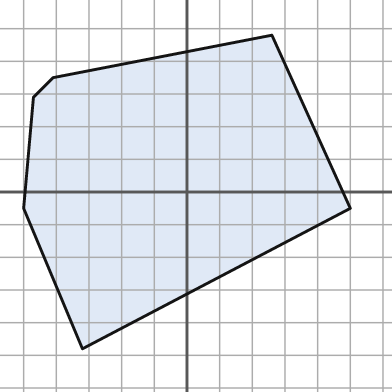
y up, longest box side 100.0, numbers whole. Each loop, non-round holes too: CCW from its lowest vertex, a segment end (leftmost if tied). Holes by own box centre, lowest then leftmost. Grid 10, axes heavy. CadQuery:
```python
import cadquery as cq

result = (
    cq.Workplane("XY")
    .moveTo(-32.0, -48.0)
    .lineTo(50.0, -5.0)
    .lineTo(26.0, 48.0)
    .lineTo(-41.0, 35.0)
    .lineTo(-47.0, 29.0)
    .lineTo(-50.0, -5.0)
    .close()
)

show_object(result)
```